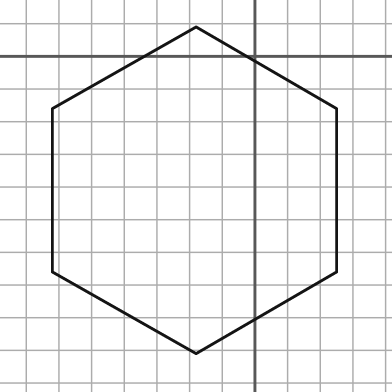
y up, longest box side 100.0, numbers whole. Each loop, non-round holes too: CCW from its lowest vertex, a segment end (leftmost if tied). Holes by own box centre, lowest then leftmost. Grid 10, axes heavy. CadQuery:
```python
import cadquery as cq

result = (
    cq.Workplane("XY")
    .moveTo(-18.0, -91.0)
    .lineTo(25.0, -66.0)
    .lineTo(25.0, -16.0)
    .lineTo(-18.0, 9.0)
    .lineTo(-62.0, -16.0)
    .lineTo(-62.0, -66.0)
    .close()
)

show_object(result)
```